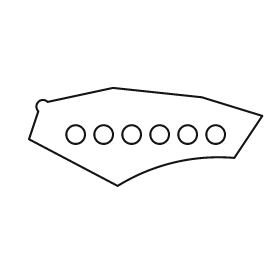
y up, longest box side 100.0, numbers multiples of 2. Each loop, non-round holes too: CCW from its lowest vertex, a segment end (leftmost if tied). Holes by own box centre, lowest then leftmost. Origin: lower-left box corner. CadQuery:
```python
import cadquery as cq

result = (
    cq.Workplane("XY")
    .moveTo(38.0, 0.0)
    .threePointArc((62.0, 10.0), (88.0, 12.0))
    .lineTo(100.0, 30.0)
    .lineTo(74.0, 38.0)
    .lineTo(36.0, 42.0)
    .lineTo(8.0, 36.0)
    .threePointArc((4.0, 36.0), (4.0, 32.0))
    .lineTo(0.0, 20.0)
    .close()
    .moveTo(20.0, 22.0)
    .circle(4.0)
    .moveTo(32.0, 22.0)
    .circle(4.0)
    .moveTo(44.0, 22.0)
    .circle(4.0)
    .moveTo(56.0, 22.0)
    .circle(4.0)
    .moveTo(68.0, 22.0)
    .circle(4.0)
    .moveTo(80.0, 22.0)
    .circle(4.0)
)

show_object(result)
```